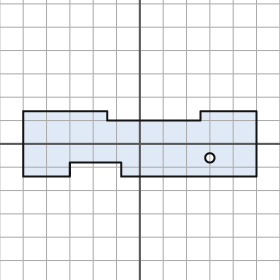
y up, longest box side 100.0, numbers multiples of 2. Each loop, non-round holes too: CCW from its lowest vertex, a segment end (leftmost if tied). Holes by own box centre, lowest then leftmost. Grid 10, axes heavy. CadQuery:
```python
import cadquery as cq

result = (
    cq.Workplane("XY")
    .moveTo(-50.0, -14.0)
    .lineTo(-30.0, -14.0)
    .lineTo(-30.0, -8.0)
    .lineTo(-8.0, -8.0)
    .lineTo(-8.0, -14.0)
    .lineTo(50.0, -14.0)
    .lineTo(50.0, 14.0)
    .lineTo(26.0, 14.0)
    .lineTo(26.0, 10.0)
    .lineTo(-14.0, 10.0)
    .lineTo(-14.0, 14.0)
    .lineTo(-50.0, 14.0)
    .close()
    .moveTo(30.0, -6.0)
    .circle(2.0)
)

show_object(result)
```